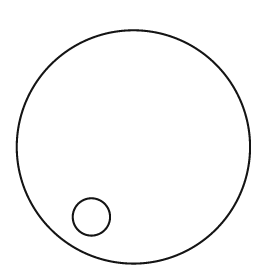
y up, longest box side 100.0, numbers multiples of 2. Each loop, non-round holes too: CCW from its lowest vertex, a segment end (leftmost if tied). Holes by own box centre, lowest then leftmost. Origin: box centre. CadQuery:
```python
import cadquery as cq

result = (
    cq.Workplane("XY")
    .moveTo(0.0, 0.0)
    .circle(50.0)
    .moveTo(-18.0, -30.0)
    .circle(8.0)
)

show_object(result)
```